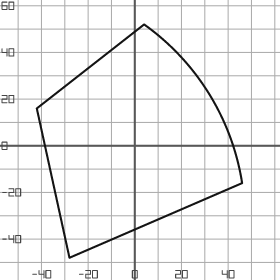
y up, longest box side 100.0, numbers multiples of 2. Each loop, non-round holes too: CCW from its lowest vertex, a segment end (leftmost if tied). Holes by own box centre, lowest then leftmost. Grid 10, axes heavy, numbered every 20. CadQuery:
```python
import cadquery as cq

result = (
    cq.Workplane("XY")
    .moveTo(-28.0, -48.0)
    .lineTo(46.0, -16.0)
    .threePointArc((32.0, 22.0), (4.0, 52.0))
    .lineTo(-42.0, 16.0)
    .close()
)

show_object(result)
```